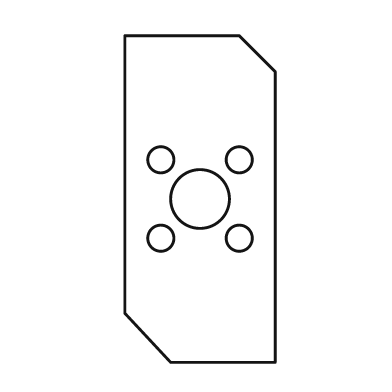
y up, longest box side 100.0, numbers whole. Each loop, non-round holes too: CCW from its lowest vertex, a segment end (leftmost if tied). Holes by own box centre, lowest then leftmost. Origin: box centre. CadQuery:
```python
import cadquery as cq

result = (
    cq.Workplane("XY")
    .moveTo(-9.0, -50.0)
    .lineTo(23.0, -50.0)
    .lineTo(23.0, 39.0)
    .lineTo(12.0, 50.0)
    .lineTo(-23.0, 50.0)
    .lineTo(-23.0, -35.0)
    .close()
    .moveTo(-12.0, -12.0)
    .circle(4.0)
    .moveTo(12.0, -12.0)
    .circle(4.0)
    .moveTo(0.0, 0.0)
    .circle(9.0)
    .moveTo(-12.0, 12.0)
    .circle(4.0)
    .moveTo(12.0, 12.0)
    .circle(4.0)
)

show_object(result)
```